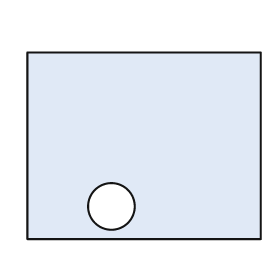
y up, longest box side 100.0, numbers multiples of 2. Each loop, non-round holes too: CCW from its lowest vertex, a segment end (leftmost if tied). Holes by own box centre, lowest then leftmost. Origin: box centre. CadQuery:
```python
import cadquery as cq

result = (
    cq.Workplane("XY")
    .moveTo(-50.0, -40.0)
    .lineTo(50.0, -40.0)
    .lineTo(50.0, 40.0)
    .lineTo(-50.0, 40.0)
    .close()
    .moveTo(-14.0, -26.0)
    .circle(10.0)
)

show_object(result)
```